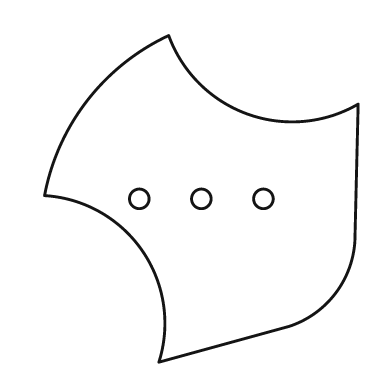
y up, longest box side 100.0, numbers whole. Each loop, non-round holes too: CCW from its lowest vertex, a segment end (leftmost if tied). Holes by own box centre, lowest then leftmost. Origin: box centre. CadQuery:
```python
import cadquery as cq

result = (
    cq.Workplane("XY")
    .moveTo(-13.0, -50.0)
    .lineTo(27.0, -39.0)
    .threePointArc((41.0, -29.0), (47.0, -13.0))
    .lineTo(48.0, 29.0)
    .threePointArc((14.0, 26.0), (-10.0, 50.0))
    .threePointArc((-35.0, 30.0), (-48.0, 1.0))
    .threePointArc((-18.0, -16.0), (-13.0, -50.0))
    .close()
    .moveTo(-19.0, 0.0)
    .circle(3.0)
    .moveTo(0.0, 0.0)
    .circle(3.0)
    .moveTo(19.0, 0.0)
    .circle(3.0)
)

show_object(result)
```